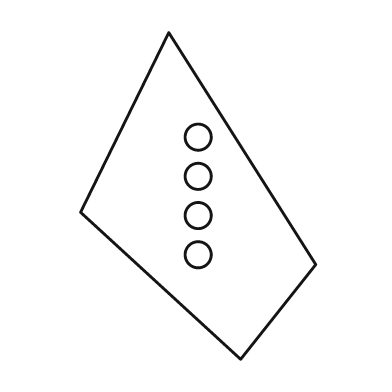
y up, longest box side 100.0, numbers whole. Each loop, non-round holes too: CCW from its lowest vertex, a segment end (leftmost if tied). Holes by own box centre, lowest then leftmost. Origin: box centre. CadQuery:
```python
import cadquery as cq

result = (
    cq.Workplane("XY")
    .moveTo(13.0, -50.0)
    .lineTo(36.0, -21.0)
    .lineTo(-9.0, 50.0)
    .lineTo(-36.0, -5.0)
    .close()
    .moveTo(0.0, -18.0)
    .circle(4.0)
    .moveTo(0.0, -6.0)
    .circle(4.0)
    .moveTo(0.0, 6.0)
    .circle(4.0)
    .moveTo(0.0, 18.0)
    .circle(4.0)
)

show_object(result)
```